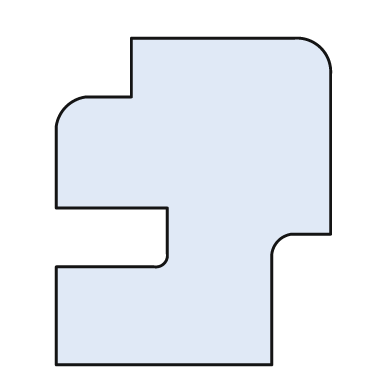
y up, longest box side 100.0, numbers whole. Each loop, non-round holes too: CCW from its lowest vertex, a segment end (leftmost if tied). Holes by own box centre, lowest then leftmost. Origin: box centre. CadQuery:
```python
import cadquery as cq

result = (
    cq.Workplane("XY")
    .moveTo(-42.0, -50.0)
    .lineTo(24.0, -50.0)
    .lineTo(24.0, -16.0)
    .threePointArc((26.0, -12.0), (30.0, -10.0))
    .lineTo(42.0, -10.0)
    .lineTo(42.0, 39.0)
    .threePointArc((39.0, 47.0), (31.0, 50.0))
    .lineTo(-19.0, 50.0)
    .lineTo(-19.0, 32.0)
    .lineTo(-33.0, 32.0)
    .threePointArc((-39.0, 29.0), (-42.0, 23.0))
    .lineTo(-42.0, -2.0)
    .lineTo(-8.0, -2.0)
    .lineTo(-8.0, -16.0)
    .threePointArc((-9.0, -19.0), (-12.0, -20.0))
    .lineTo(-42.0, -20.0)
    .close()
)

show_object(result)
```